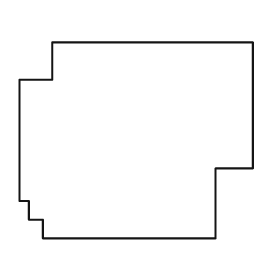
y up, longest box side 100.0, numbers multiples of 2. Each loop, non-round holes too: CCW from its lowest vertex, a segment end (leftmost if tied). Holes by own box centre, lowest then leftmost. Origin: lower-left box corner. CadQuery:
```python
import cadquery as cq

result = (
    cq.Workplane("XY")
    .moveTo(10.0, 0.0)
    .lineTo(84.0, 0.0)
    .lineTo(84.0, 30.0)
    .lineTo(100.0, 30.0)
    .lineTo(100.0, 84.0)
    .lineTo(14.0, 84.0)
    .lineTo(14.0, 68.0)
    .lineTo(0.0, 68.0)
    .lineTo(0.0, 16.0)
    .lineTo(4.0, 16.0)
    .lineTo(4.0, 8.0)
    .lineTo(10.0, 8.0)
    .close()
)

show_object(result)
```